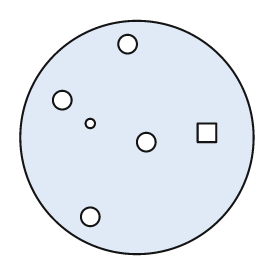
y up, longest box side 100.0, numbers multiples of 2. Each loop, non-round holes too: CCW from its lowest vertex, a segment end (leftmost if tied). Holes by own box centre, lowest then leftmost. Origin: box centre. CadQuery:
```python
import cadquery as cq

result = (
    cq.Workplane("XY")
    .moveTo(0.0, 0.0)
    .circle(50.0)
    .moveTo(-20.0, -34.0)
    .circle(4.0)
    .moveTo(4.0, -2.0)
    .circle(4.0)
    .moveTo(26.0, -2.0)
    .lineTo(34.0, -2.0)
    .lineTo(34.0, 6.0)
    .lineTo(26.0, 6.0)
    .close()
    .moveTo(-20.0, 6.0)
    .circle(2.0)
    .moveTo(-32.0, 16.0)
    .circle(4.0)
    .moveTo(-4.0, 40.0)
    .circle(4.0)
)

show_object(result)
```